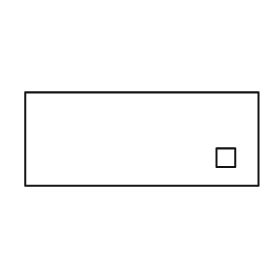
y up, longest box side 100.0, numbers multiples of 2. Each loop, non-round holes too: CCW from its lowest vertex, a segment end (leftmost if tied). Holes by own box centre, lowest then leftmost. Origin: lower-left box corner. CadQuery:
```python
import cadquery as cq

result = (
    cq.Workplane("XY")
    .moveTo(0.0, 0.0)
    .lineTo(100.0, 0.0)
    .lineTo(100.0, 40.0)
    .lineTo(0.0, 40.0)
    .close()
    .moveTo(82.0, 8.0)
    .lineTo(90.0, 8.0)
    .lineTo(90.0, 16.0)
    .lineTo(82.0, 16.0)
    .close()
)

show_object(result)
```